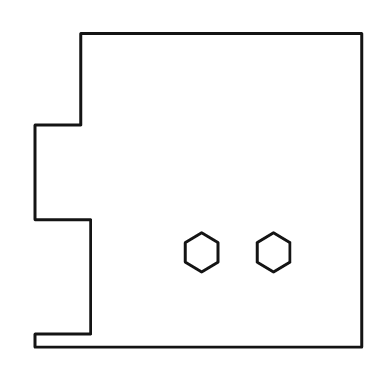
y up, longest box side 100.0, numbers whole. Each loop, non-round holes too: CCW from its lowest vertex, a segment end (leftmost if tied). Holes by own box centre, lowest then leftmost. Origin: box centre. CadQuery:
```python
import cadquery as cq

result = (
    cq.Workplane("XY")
    .moveTo(-50.0, -48.0)
    .lineTo(50.0, -48.0)
    .lineTo(50.0, 48.0)
    .lineTo(-36.0, 48.0)
    .lineTo(-36.0, 20.0)
    .lineTo(-50.0, 20.0)
    .lineTo(-50.0, -9.0)
    .lineTo(-33.0, -9.0)
    .lineTo(-33.0, -44.0)
    .lineTo(-50.0, -44.0)
    .close()
    .moveTo(1.0, -25.0)
    .lineTo(6.0, -22.0)
    .lineTo(6.0, -16.0)
    .lineTo(1.0, -13.0)
    .lineTo(-4.0, -16.0)
    .lineTo(-4.0, -22.0)
    .close()
    .moveTo(23.0, -25.0)
    .lineTo(28.0, -22.0)
    .lineTo(28.0, -16.0)
    .lineTo(23.0, -13.0)
    .lineTo(18.0, -16.0)
    .lineTo(18.0, -22.0)
    .close()
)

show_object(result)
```